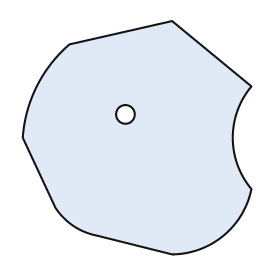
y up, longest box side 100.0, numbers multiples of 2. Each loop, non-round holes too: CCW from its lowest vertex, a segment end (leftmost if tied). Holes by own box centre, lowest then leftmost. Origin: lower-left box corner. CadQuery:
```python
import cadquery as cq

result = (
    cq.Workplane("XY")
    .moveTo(64.0, 0.0)
    .threePointArc((86.0, 8.0), (98.0, 28.0))
    .threePointArc((90.0, 50.0), (98.0, 72.0))
    .lineTo(64.0, 100.0)
    .lineTo(20.0, 90.0)
    .threePointArc((6.0, 72.0), (0.0, 50.0))
    .lineTo(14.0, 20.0)
    .threePointArc((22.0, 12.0), (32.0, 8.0))
    .close()
    .moveTo(44.0, 60.0)
    .circle(4.0)
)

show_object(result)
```